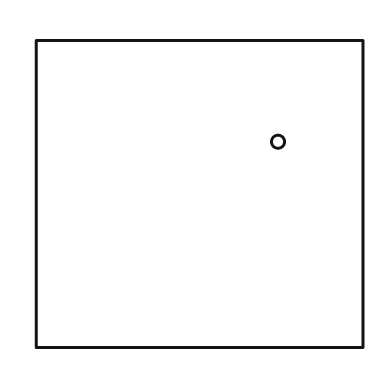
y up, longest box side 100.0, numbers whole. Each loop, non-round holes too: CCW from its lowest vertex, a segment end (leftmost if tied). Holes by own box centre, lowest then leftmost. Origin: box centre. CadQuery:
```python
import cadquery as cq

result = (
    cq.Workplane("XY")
    .moveTo(-50.0, -47.0)
    .lineTo(50.0, -47.0)
    .lineTo(50.0, 47.0)
    .lineTo(-50.0, 47.0)
    .close()
    .moveTo(24.0, 16.0)
    .circle(2.0)
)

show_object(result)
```